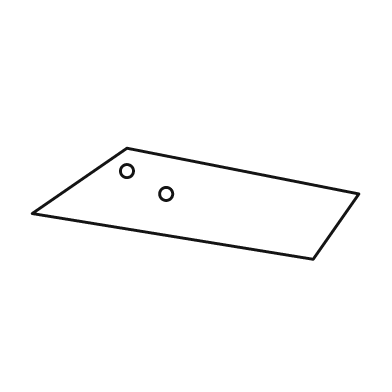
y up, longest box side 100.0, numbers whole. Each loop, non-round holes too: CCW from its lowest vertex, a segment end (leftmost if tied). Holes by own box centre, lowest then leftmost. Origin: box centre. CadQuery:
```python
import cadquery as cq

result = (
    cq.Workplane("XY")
    .moveTo(36.0, -17.0)
    .lineTo(50.0, 3.0)
    .lineTo(-21.0, 17.0)
    .lineTo(-50.0, -3.0)
    .close()
    .moveTo(-9.0, 3.0)
    .circle(2.0)
    .moveTo(-21.0, 10.0)
    .circle(2.0)
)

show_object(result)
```